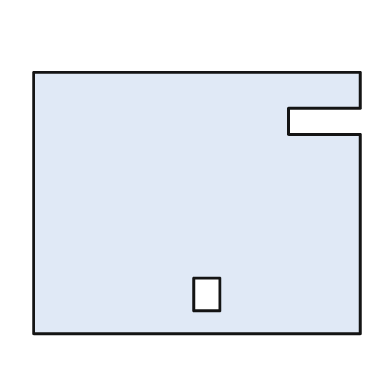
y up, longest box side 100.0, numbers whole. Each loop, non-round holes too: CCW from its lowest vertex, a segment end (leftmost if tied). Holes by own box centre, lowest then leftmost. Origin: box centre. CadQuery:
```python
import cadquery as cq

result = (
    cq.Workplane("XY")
    .moveTo(-50.0, -40.0)
    .lineTo(50.0, -40.0)
    .lineTo(50.0, 21.0)
    .lineTo(28.0, 21.0)
    .lineTo(28.0, 29.0)
    .lineTo(50.0, 29.0)
    .lineTo(50.0, 40.0)
    .lineTo(-50.0, 40.0)
    .close()
    .moveTo(-1.0, -33.0)
    .lineTo(7.0, -33.0)
    .lineTo(7.0, -23.0)
    .lineTo(-1.0, -23.0)
    .close()
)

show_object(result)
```